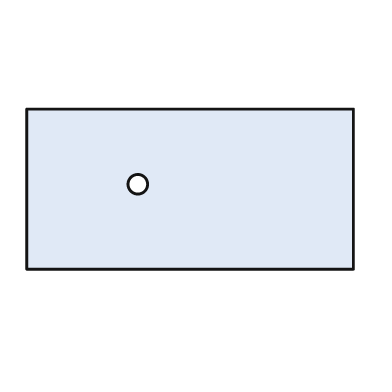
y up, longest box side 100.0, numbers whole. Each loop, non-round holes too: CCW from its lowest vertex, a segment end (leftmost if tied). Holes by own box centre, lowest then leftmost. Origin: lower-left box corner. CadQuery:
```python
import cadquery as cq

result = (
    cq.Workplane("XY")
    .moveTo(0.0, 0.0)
    .lineTo(100.0, 0.0)
    .lineTo(100.0, 49.0)
    .lineTo(0.0, 49.0)
    .close()
    .moveTo(34.0, 26.0)
    .circle(3.0)
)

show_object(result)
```